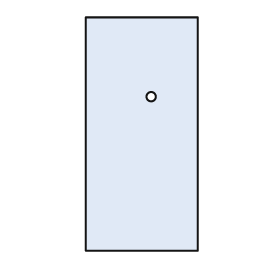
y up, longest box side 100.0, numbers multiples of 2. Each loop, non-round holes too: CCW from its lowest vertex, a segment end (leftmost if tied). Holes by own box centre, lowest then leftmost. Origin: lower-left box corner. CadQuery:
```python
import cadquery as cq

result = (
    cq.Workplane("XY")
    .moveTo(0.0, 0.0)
    .lineTo(48.0, 0.0)
    .lineTo(48.0, 100.0)
    .lineTo(0.0, 100.0)
    .close()
    .moveTo(28.0, 66.0)
    .circle(2.0)
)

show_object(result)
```